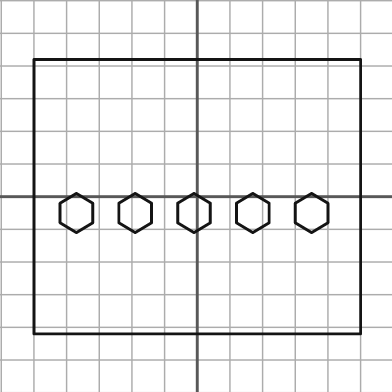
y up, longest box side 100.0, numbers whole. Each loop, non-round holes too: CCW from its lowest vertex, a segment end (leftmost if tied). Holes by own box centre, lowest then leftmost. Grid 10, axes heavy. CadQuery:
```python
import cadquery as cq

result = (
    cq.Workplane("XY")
    .moveTo(-50.0, -42.0)
    .lineTo(50.0, -42.0)
    .lineTo(50.0, 42.0)
    .lineTo(-50.0, 42.0)
    .close()
    .moveTo(-37.0, -11.0)
    .lineTo(-32.0, -8.0)
    .lineTo(-32.0, -2.0)
    .lineTo(-37.0, 1.0)
    .lineTo(-42.0, -2.0)
    .lineTo(-42.0, -8.0)
    .close()
    .moveTo(-19.0, -11.0)
    .lineTo(-14.0, -8.0)
    .lineTo(-14.0, -2.0)
    .lineTo(-19.0, 1.0)
    .lineTo(-24.0, -2.0)
    .lineTo(-24.0, -8.0)
    .close()
    .moveTo(-1.0, -11.0)
    .lineTo(4.0, -8.0)
    .lineTo(4.0, -2.0)
    .lineTo(-1.0, 1.0)
    .lineTo(-6.0, -2.0)
    .lineTo(-6.0, -8.0)
    .close()
    .moveTo(17.0, -11.0)
    .lineTo(22.0, -8.0)
    .lineTo(22.0, -2.0)
    .lineTo(17.0, 1.0)
    .lineTo(12.0, -2.0)
    .lineTo(12.0, -8.0)
    .close()
    .moveTo(35.0, -11.0)
    .lineTo(40.0, -8.0)
    .lineTo(40.0, -2.0)
    .lineTo(35.0, 1.0)
    .lineTo(30.0, -2.0)
    .lineTo(30.0, -8.0)
    .close()
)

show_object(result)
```